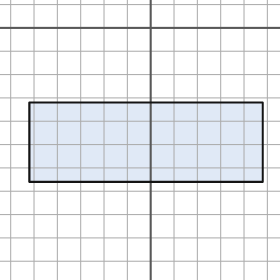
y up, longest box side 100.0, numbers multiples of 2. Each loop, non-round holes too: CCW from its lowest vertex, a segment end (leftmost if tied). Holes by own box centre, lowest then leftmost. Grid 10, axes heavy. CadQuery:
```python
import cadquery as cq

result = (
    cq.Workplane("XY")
    .moveTo(-52.0, -66.0)
    .lineTo(48.0, -66.0)
    .lineTo(48.0, -32.0)
    .lineTo(-52.0, -32.0)
    .close()
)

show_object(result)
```